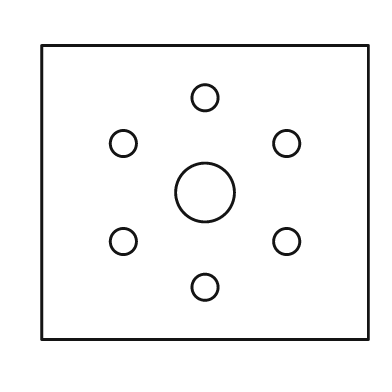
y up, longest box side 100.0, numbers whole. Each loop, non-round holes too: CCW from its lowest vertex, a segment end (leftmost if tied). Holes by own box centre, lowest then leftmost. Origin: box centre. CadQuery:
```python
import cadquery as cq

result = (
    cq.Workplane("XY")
    .moveTo(-50.0, -45.0)
    .lineTo(50.0, -45.0)
    .lineTo(50.0, 45.0)
    .lineTo(-50.0, 45.0)
    .close()
    .moveTo(0.0, -29.0)
    .circle(4.0)
    .moveTo(-25.0, -15.0)
    .circle(4.0)
    .moveTo(25.0, -15.0)
    .circle(4.0)
    .moveTo(0.0, 0.0)
    .circle(9.0)
    .moveTo(-25.0, 15.0)
    .circle(4.0)
    .moveTo(25.0, 15.0)
    .circle(4.0)
    .moveTo(0.0, 29.0)
    .circle(4.0)
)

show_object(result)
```